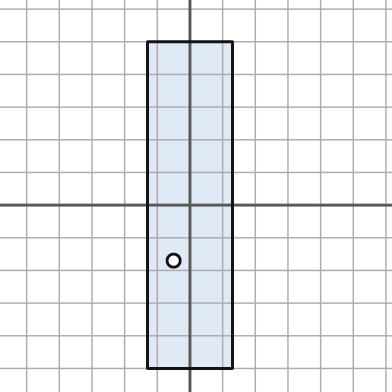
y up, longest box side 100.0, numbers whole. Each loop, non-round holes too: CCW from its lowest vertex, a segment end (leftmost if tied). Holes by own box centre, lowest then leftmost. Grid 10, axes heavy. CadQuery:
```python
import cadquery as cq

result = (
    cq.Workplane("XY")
    .moveTo(-13.0, -50.0)
    .lineTo(13.0, -50.0)
    .lineTo(13.0, 50.0)
    .lineTo(-13.0, 50.0)
    .close()
    .moveTo(-5.0, -17.0)
    .circle(2.0)
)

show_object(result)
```